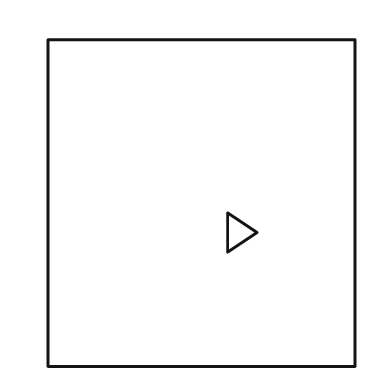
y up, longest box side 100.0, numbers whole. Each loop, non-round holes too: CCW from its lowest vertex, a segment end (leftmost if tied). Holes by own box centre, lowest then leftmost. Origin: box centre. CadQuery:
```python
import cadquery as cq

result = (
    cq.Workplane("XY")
    .moveTo(-47.0, -50.0)
    .lineTo(47.0, -50.0)
    .lineTo(47.0, 50.0)
    .lineTo(-47.0, 50.0)
    .close()
    .moveTo(8.0, -15.0)
    .lineTo(17.0, -9.0)
    .lineTo(8.0, -3.0)
    .close()
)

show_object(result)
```